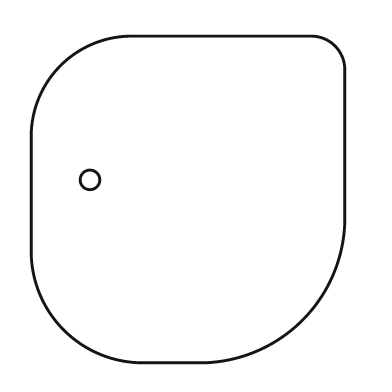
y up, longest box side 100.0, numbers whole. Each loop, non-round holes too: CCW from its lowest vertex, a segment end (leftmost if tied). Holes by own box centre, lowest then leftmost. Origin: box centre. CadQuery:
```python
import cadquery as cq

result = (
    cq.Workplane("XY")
    .moveTo(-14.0, -50.0)
    .lineTo(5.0, -50.0)
    .threePointArc((35.0, -37.0), (48.0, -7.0))
    .lineTo(48.0, 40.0)
    .threePointArc((45.0, 47.0), (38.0, 50.0))
    .lineTo(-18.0, 50.0)
    .threePointArc((-39.0, 41.0), (-48.0, 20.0))
    .lineTo(-48.0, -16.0)
    .threePointArc((-38.0, -40.0), (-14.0, -50.0))
    .close()
    .moveTo(-30.0, 6.0)
    .circle(3.0)
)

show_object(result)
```